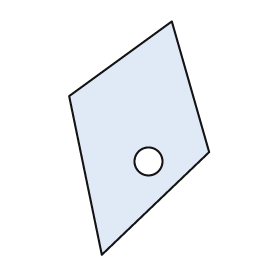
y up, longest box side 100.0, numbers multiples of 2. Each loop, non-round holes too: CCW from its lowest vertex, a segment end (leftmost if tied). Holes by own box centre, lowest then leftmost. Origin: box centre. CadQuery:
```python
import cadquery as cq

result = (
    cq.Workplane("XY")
    .moveTo(-16.0, -50.0)
    .lineTo(30.0, -6.0)
    .lineTo(14.0, 50.0)
    .lineTo(-30.0, 18.0)
    .close()
    .moveTo(4.0, -10.0)
    .circle(6.0)
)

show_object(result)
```